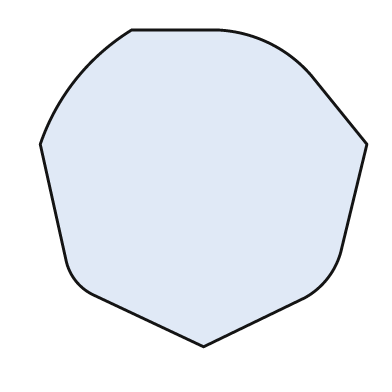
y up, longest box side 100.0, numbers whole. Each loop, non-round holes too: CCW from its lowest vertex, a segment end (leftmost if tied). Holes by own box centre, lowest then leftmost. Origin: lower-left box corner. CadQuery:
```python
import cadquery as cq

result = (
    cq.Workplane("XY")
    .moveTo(50.0, 0.0)
    .lineTo(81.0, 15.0)
    .threePointArc((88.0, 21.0), (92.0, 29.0))
    .lineTo(100.0, 62.0)
    .lineTo(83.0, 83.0)
    .threePointArc((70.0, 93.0), (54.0, 97.0))
    .lineTo(28.0, 97.0)
    .threePointArc((11.0, 82.0), (0.0, 62.0))
    .lineTo(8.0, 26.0)
    .threePointArc((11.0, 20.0), (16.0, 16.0))
    .close()
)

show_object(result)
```